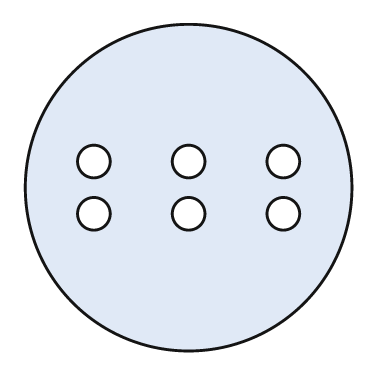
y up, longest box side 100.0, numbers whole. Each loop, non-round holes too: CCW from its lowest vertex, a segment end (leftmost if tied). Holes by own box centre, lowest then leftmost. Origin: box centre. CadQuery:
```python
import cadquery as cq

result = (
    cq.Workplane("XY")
    .moveTo(0.0, 0.0)
    .circle(50.0)
    .moveTo(-29.0, -8.0)
    .circle(5.0)
    .moveTo(0.0, -8.0)
    .circle(5.0)
    .moveTo(29.0, -8.0)
    .circle(5.0)
    .moveTo(-29.0, 8.0)
    .circle(5.0)
    .moveTo(0.0, 8.0)
    .circle(5.0)
    .moveTo(29.0, 8.0)
    .circle(5.0)
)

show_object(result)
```